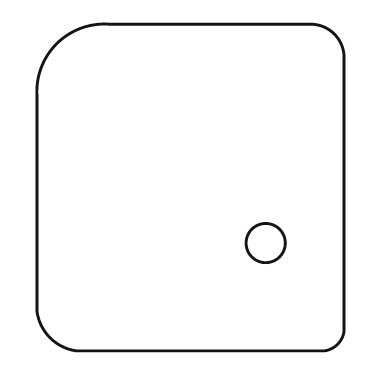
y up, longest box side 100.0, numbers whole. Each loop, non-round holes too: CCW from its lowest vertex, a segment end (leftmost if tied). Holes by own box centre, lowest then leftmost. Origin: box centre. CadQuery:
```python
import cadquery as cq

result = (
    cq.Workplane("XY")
    .moveTo(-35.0, -50.0)
    .lineTo(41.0, -50.0)
    .threePointArc((45.0, -48.0), (47.0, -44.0))
    .lineTo(47.0, 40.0)
    .threePointArc((44.0, 47.0), (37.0, 50.0))
    .lineTo(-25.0, 50.0)
    .threePointArc((-41.0, 44.0), (-47.0, 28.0))
    .lineTo(-47.0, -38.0)
    .threePointArc((-43.0, -46.0), (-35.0, -50.0))
    .close()
    .moveTo(23.0, -17.0)
    .circle(6.0)
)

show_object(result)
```